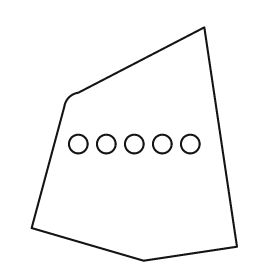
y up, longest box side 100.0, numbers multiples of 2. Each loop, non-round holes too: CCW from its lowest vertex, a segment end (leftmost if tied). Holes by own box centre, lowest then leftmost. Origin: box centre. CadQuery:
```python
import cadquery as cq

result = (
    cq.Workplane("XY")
    .moveTo(4.0, -50.0)
    .lineTo(44.0, -44.0)
    .lineTo(30.0, 50.0)
    .lineTo(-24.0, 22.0)
    .threePointArc((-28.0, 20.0), (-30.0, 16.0))
    .lineTo(-44.0, -36.0)
    .close()
    .moveTo(-24.0, 0.0)
    .circle(4.0)
    .moveTo(-12.0, 0.0)
    .circle(4.0)
    .moveTo(0.0, 0.0)
    .circle(4.0)
    .moveTo(12.0, 0.0)
    .circle(4.0)
    .moveTo(24.0, 0.0)
    .circle(4.0)
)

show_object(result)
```